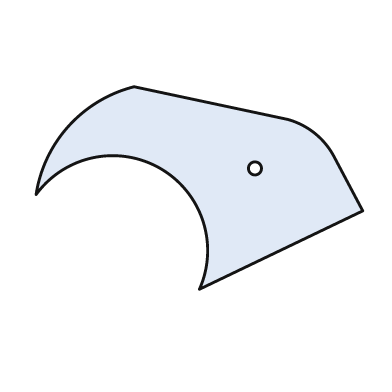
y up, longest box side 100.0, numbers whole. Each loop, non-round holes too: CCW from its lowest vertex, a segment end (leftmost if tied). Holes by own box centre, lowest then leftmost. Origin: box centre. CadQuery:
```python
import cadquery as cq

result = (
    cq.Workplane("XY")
    .moveTo(0.0, -31.0)
    .lineTo(50.0, -7.0)
    .lineTo(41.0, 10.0)
    .threePointArc((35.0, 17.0), (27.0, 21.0))
    .lineTo(-20.0, 31.0)
    .threePointArc((-40.0, 19.0), (-50.0, -2.0))
    .threePointArc((-12.0, 6.0), (0.0, -31.0))
    .close()
    .moveTo(17.0, 6.0)
    .circle(2.0)
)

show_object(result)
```